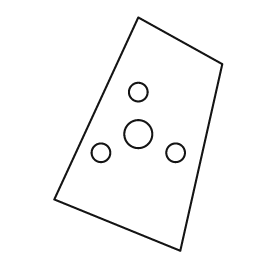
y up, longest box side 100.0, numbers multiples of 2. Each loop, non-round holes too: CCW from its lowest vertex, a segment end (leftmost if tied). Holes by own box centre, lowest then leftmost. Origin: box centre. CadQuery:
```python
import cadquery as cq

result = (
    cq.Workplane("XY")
    .moveTo(18.0, -50.0)
    .lineTo(36.0, 30.0)
    .lineTo(0.0, 50.0)
    .lineTo(-36.0, -28.0)
    .close()
    .moveTo(-16.0, -8.0)
    .circle(4.0)
    .moveTo(16.0, -8.0)
    .circle(4.0)
    .moveTo(0.0, 0.0)
    .circle(6.0)
    .moveTo(0.0, 18.0)
    .circle(4.0)
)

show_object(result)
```